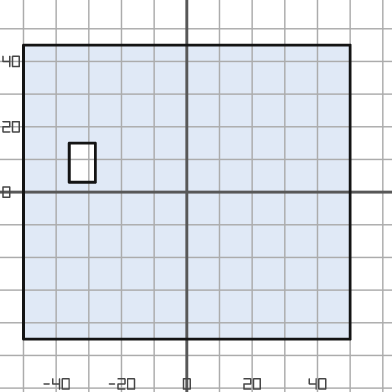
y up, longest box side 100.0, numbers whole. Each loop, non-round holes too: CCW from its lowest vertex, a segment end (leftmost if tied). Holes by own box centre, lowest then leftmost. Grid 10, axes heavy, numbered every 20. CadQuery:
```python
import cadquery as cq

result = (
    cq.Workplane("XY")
    .moveTo(-50.0, -45.0)
    .lineTo(50.0, -45.0)
    .lineTo(50.0, 45.0)
    .lineTo(-50.0, 45.0)
    .close()
    .moveTo(-36.0, 3.0)
    .lineTo(-28.0, 3.0)
    .lineTo(-28.0, 15.0)
    .lineTo(-36.0, 15.0)
    .close()
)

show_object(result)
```